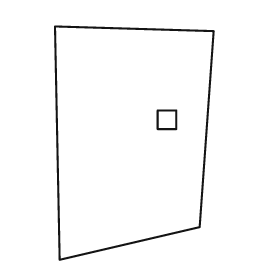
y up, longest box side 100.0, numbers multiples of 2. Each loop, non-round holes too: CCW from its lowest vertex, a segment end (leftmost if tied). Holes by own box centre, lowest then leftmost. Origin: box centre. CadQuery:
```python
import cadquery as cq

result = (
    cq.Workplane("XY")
    .moveTo(-32.0, -50.0)
    .lineTo(28.0, -36.0)
    .lineTo(34.0, 48.0)
    .lineTo(-34.0, 50.0)
    .close()
    .moveTo(10.0, 6.0)
    .lineTo(18.0, 6.0)
    .lineTo(18.0, 14.0)
    .lineTo(10.0, 14.0)
    .close()
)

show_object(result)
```